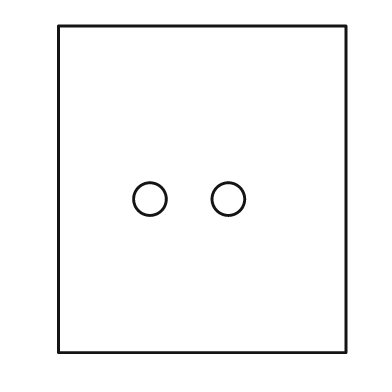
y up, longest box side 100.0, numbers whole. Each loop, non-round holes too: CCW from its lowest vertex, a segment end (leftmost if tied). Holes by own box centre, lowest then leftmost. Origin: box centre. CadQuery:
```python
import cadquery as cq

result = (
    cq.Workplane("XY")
    .moveTo(-44.0, -50.0)
    .lineTo(44.0, -50.0)
    .lineTo(44.0, 50.0)
    .lineTo(-44.0, 50.0)
    .close()
    .moveTo(-16.0, -3.0)
    .circle(5.0)
    .moveTo(8.0, -3.0)
    .circle(5.0)
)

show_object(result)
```